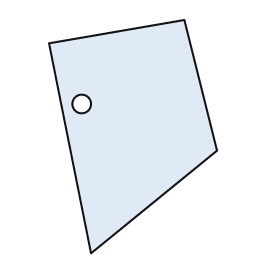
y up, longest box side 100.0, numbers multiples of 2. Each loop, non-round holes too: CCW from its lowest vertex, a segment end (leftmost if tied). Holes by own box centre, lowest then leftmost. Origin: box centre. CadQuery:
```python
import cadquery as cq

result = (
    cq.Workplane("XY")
    .moveTo(-18.0, -50.0)
    .lineTo(36.0, -6.0)
    .lineTo(22.0, 50.0)
    .lineTo(-36.0, 40.0)
    .close()
    .moveTo(-22.0, 14.0)
    .circle(4.0)
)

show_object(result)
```